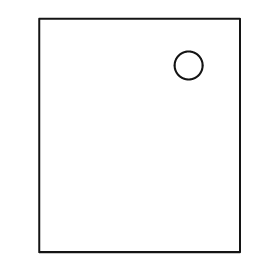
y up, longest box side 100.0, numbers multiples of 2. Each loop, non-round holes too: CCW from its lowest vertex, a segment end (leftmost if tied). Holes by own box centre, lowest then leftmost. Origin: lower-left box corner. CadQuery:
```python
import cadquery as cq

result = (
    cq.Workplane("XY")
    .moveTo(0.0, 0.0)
    .lineTo(86.0, 0.0)
    .lineTo(86.0, 100.0)
    .lineTo(0.0, 100.0)
    .close()
    .moveTo(64.0, 80.0)
    .circle(6.0)
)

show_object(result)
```